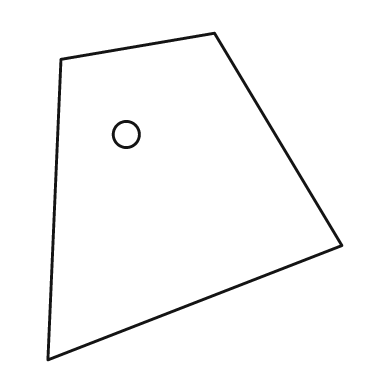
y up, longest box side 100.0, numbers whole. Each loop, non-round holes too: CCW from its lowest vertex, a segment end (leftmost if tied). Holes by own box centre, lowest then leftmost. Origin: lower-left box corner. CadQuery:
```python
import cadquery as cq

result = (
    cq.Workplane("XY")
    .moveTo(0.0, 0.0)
    .lineTo(90.0, 35.0)
    .lineTo(51.0, 100.0)
    .lineTo(4.0, 92.0)
    .close()
    .moveTo(24.0, 69.0)
    .circle(4.0)
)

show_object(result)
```